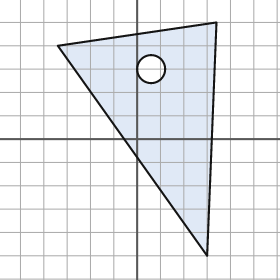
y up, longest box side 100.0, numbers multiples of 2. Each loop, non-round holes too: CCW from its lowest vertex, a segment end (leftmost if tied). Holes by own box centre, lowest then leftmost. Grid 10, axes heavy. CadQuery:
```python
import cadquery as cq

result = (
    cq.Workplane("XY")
    .moveTo(30.0, -50.0)
    .lineTo(34.0, 50.0)
    .lineTo(-34.0, 40.0)
    .close()
    .moveTo(6.0, 30.0)
    .circle(6.0)
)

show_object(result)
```